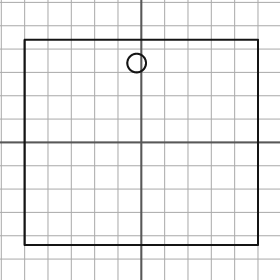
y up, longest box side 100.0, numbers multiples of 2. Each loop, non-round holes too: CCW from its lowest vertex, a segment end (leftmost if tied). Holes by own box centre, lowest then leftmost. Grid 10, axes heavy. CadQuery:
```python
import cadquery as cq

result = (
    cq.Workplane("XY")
    .moveTo(-50.0, -44.0)
    .lineTo(50.0, -44.0)
    .lineTo(50.0, 44.0)
    .lineTo(-50.0, 44.0)
    .close()
    .moveTo(-2.0, 34.0)
    .circle(4.0)
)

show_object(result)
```